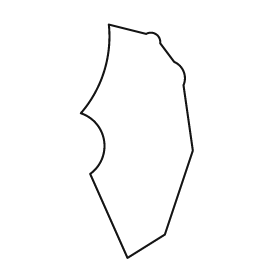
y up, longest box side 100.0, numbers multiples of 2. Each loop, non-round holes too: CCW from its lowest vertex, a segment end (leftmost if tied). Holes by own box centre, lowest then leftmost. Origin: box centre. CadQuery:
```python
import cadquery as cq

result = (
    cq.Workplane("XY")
    .moveTo(-4.0, -50.0)
    .lineTo(12.0, -40.0)
    .lineTo(24.0, -4.0)
    .lineTo(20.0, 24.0)
    .threePointArc((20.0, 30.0), (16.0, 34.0))
    .lineTo(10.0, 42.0)
    .threePointArc((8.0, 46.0), (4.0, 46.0))
    .lineTo(-12.0, 50.0)
    .threePointArc((-14.0, 30.0), (-24.0, 12.0))
    .threePointArc((-14.0, 0.0), (-20.0, -14.0))
    .close()
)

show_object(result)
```